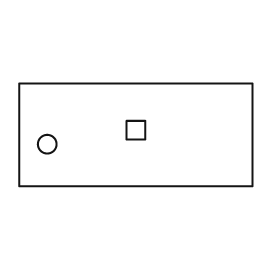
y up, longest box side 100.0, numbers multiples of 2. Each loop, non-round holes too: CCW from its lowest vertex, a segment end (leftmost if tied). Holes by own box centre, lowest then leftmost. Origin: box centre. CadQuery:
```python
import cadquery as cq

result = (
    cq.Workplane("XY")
    .moveTo(-50.0, -22.0)
    .lineTo(50.0, -22.0)
    .lineTo(50.0, 22.0)
    .lineTo(-50.0, 22.0)
    .close()
    .moveTo(-38.0, -4.0)
    .circle(4.0)
    .moveTo(-4.0, -2.0)
    .lineTo(4.0, -2.0)
    .lineTo(4.0, 6.0)
    .lineTo(-4.0, 6.0)
    .close()
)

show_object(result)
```